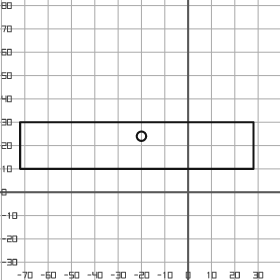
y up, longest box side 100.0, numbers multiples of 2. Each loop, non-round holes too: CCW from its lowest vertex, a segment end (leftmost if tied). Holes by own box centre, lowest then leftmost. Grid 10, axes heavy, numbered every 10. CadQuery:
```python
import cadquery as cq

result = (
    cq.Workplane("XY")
    .moveTo(-72.0, 10.0)
    .lineTo(28.0, 10.0)
    .lineTo(28.0, 30.0)
    .lineTo(-72.0, 30.0)
    .close()
    .moveTo(-20.0, 24.0)
    .circle(2.0)
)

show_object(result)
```